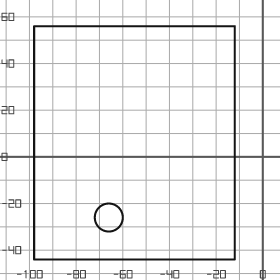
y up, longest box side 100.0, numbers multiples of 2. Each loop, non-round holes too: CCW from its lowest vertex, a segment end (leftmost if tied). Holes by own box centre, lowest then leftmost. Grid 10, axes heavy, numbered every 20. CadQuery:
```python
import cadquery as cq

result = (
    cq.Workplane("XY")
    .moveTo(-98.0, -44.0)
    .lineTo(-12.0, -44.0)
    .lineTo(-12.0, 56.0)
    .lineTo(-98.0, 56.0)
    .close()
    .moveTo(-66.0, -26.0)
    .circle(6.0)
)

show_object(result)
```